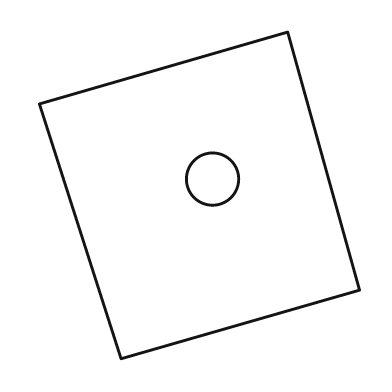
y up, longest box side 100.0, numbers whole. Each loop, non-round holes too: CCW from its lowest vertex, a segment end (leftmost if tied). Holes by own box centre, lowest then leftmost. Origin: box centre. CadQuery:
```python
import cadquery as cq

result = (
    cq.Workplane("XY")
    .moveTo(-24.0, -50.0)
    .lineTo(49.0, -29.0)
    .lineTo(27.0, 50.0)
    .lineTo(-49.0, 28.0)
    .close()
    .moveTo(4.0, 5.0)
    .circle(8.0)
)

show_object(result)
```